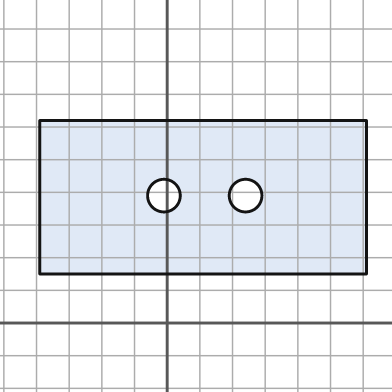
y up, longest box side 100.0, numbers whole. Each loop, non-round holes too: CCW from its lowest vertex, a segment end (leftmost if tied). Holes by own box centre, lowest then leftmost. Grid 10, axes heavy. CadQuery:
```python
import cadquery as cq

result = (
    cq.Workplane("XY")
    .moveTo(-39.0, 15.0)
    .lineTo(61.0, 15.0)
    .lineTo(61.0, 62.0)
    .lineTo(-39.0, 62.0)
    .close()
    .moveTo(-1.0, 39.0)
    .circle(5.0)
    .moveTo(24.0, 39.0)
    .circle(5.0)
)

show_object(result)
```